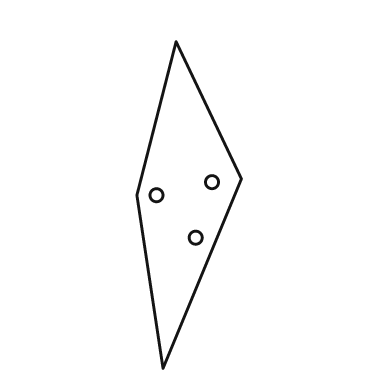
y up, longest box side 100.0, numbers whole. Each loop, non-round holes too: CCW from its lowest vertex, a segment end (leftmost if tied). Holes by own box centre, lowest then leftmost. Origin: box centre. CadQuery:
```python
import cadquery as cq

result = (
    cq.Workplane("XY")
    .moveTo(-8.0, -50.0)
    .lineTo(16.0, 8.0)
    .lineTo(-4.0, 50.0)
    .lineTo(-16.0, 3.0)
    .close()
    .moveTo(2.0, -10.0)
    .circle(2.0)
    .moveTo(-10.0, 3.0)
    .circle(2.0)
    .moveTo(7.0, 7.0)
    .circle(2.0)
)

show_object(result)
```